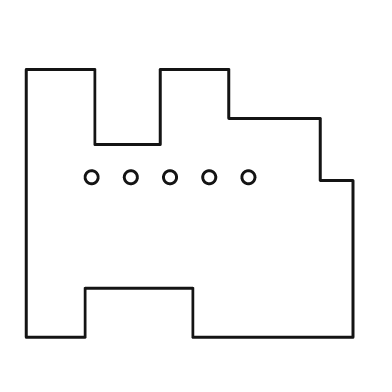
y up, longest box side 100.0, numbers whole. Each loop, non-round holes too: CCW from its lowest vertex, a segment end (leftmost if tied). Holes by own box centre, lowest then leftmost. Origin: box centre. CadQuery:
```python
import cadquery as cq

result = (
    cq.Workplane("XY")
    .moveTo(-50.0, -41.0)
    .lineTo(-32.0, -41.0)
    .lineTo(-32.0, -26.0)
    .lineTo(1.0, -26.0)
    .lineTo(1.0, -41.0)
    .lineTo(50.0, -41.0)
    .lineTo(50.0, 7.0)
    .lineTo(40.0, 7.0)
    .lineTo(40.0, 26.0)
    .lineTo(12.0, 26.0)
    .lineTo(12.0, 41.0)
    .lineTo(-9.0, 41.0)
    .lineTo(-9.0, 18.0)
    .lineTo(-29.0, 18.0)
    .lineTo(-29.0, 41.0)
    .lineTo(-50.0, 41.0)
    .close()
    .moveTo(-30.0, 8.0)
    .circle(2.0)
    .moveTo(-18.0, 8.0)
    .circle(2.0)
    .moveTo(-6.0, 8.0)
    .circle(2.0)
    .moveTo(6.0, 8.0)
    .circle(2.0)
    .moveTo(18.0, 8.0)
    .circle(2.0)
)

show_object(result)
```